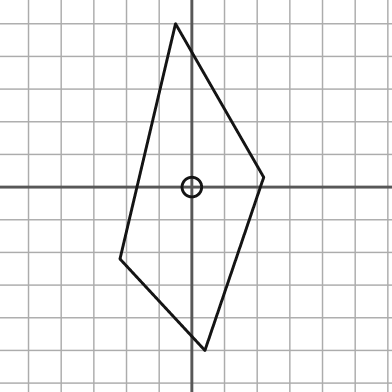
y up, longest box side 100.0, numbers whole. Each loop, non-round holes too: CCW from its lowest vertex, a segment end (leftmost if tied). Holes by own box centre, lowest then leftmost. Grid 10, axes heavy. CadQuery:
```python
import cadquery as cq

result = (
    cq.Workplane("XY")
    .moveTo(4.0, -50.0)
    .lineTo(22.0, 3.0)
    .lineTo(-5.0, 50.0)
    .lineTo(-22.0, -22.0)
    .close()
    .moveTo(0.0, 0.0)
    .circle(3.0)
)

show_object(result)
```